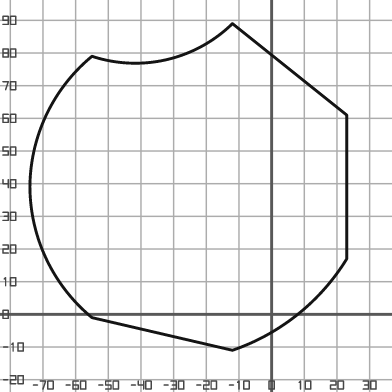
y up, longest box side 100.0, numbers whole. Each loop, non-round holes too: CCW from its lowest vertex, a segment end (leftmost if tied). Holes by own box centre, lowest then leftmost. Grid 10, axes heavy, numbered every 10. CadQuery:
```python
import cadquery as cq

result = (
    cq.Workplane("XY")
    .moveTo(-12.0, -11.0)
    .threePointArc((8.0, 0.0), (23.0, 17.0))
    .lineTo(23.0, 61.0)
    .lineTo(-12.0, 89.0)
    .threePointArc((-32.0, 78.0), (-55.0, 79.0))
    .threePointArc((-69.0, 61.0), (-74.0, 39.0))
    .threePointArc((-69.0, 17.0), (-55.0, -1.0))
    .close()
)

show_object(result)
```